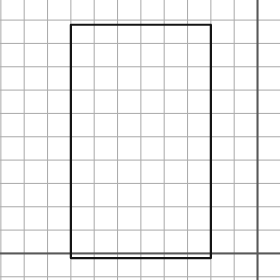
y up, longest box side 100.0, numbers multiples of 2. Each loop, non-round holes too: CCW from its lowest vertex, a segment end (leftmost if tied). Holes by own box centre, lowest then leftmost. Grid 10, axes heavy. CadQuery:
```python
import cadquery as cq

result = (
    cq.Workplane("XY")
    .moveTo(-80.0, -2.0)
    .lineTo(-20.0, -2.0)
    .lineTo(-20.0, 98.0)
    .lineTo(-80.0, 98.0)
    .close()
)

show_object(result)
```